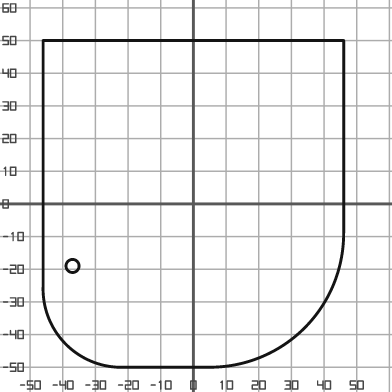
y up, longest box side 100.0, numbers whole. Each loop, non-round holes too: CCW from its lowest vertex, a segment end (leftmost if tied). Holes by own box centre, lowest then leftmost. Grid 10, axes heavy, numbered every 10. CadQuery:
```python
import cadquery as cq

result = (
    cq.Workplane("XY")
    .moveTo(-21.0, -50.0)
    .lineTo(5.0, -50.0)
    .threePointArc((34.0, -38.0), (46.0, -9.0))
    .lineTo(46.0, 50.0)
    .lineTo(-46.0, 50.0)
    .lineTo(-46.0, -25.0)
    .threePointArc((-39.0, -43.0), (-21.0, -50.0))
    .close()
    .moveTo(-37.0, -19.0)
    .circle(2.0)
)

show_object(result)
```